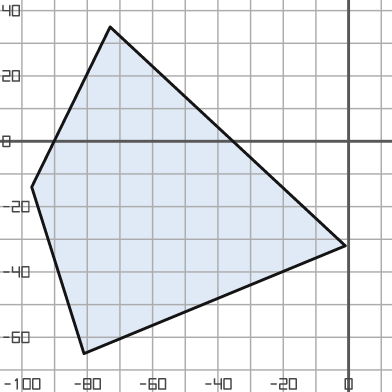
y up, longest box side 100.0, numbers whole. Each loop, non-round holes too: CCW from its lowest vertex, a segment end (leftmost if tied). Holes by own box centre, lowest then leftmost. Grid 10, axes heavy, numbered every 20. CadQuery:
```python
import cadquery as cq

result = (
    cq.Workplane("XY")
    .moveTo(-81.0, -65.0)
    .lineTo(-1.0, -32.0)
    .lineTo(-73.0, 35.0)
    .lineTo(-97.0, -14.0)
    .close()
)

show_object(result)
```